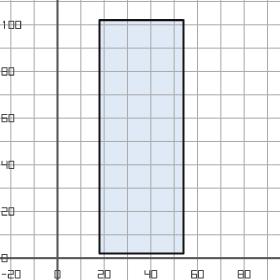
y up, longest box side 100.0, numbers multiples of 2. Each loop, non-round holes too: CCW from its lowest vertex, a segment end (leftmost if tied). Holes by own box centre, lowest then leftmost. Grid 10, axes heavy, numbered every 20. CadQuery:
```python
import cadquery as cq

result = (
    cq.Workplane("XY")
    .moveTo(18.0, 2.0)
    .lineTo(54.0, 2.0)
    .lineTo(54.0, 102.0)
    .lineTo(18.0, 102.0)
    .close()
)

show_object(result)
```